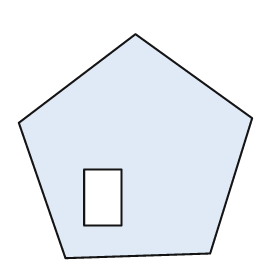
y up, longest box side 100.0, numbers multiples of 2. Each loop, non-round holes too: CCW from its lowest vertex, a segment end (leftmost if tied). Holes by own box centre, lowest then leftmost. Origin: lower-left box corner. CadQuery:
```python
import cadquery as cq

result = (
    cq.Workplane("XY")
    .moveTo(20.0, 0.0)
    .lineTo(82.0, 2.0)
    .lineTo(100.0, 60.0)
    .lineTo(50.0, 96.0)
    .lineTo(0.0, 58.0)
    .close()
    .moveTo(28.0, 14.0)
    .lineTo(44.0, 14.0)
    .lineTo(44.0, 38.0)
    .lineTo(28.0, 38.0)
    .close()
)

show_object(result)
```